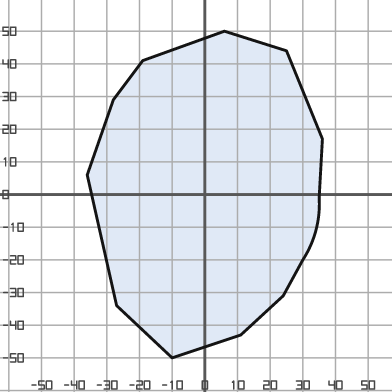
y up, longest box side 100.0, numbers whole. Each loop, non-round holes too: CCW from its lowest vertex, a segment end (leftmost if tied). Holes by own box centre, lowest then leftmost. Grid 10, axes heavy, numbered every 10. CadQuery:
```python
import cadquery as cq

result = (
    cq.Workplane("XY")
    .moveTo(-10.0, -50.0)
    .lineTo(11.0, -43.0)
    .lineTo(24.0, -31.0)
    .lineTo(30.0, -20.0)
    .threePointArc((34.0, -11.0), (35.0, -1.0))
    .lineTo(36.0, 17.0)
    .lineTo(25.0, 44.0)
    .lineTo(6.0, 50.0)
    .lineTo(-19.0, 41.0)
    .lineTo(-28.0, 29.0)
    .lineTo(-36.0, 6.0)
    .lineTo(-27.0, -34.0)
    .close()
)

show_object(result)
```